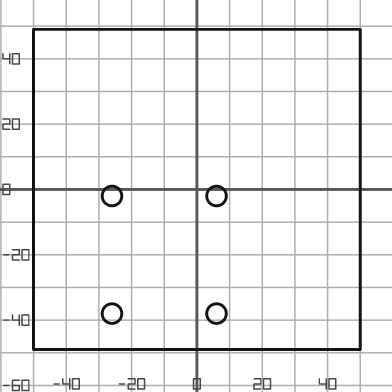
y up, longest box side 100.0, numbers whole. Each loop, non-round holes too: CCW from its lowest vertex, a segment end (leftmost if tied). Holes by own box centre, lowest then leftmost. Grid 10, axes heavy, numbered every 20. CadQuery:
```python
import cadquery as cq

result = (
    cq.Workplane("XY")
    .moveTo(-50.0, -49.0)
    .lineTo(50.0, -49.0)
    .lineTo(50.0, 49.0)
    .lineTo(-50.0, 49.0)
    .close()
    .moveTo(-26.0, -38.0)
    .circle(3.0)
    .moveTo(6.0, -38.0)
    .circle(3.0)
    .moveTo(-26.0, -2.0)
    .circle(3.0)
    .moveTo(6.0, -2.0)
    .circle(3.0)
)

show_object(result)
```